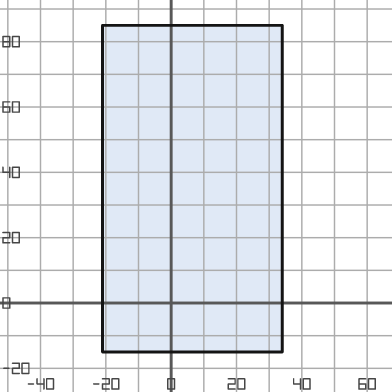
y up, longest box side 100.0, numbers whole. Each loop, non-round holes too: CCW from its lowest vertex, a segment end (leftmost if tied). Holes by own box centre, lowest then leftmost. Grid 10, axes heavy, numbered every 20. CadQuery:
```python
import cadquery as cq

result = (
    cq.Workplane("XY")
    .moveTo(-21.0, -15.0)
    .lineTo(34.0, -15.0)
    .lineTo(34.0, 85.0)
    .lineTo(-21.0, 85.0)
    .close()
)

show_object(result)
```